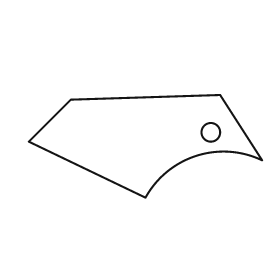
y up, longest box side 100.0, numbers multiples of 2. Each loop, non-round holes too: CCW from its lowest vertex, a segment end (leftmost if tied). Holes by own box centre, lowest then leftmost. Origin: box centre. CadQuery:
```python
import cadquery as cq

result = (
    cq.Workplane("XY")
    .moveTo(0.0, -22.0)
    .threePointArc((22.0, -4.0), (50.0, -6.0))
    .lineTo(32.0, 22.0)
    .lineTo(-32.0, 20.0)
    .lineTo(-50.0, 2.0)
    .close()
    .moveTo(28.0, 6.0)
    .circle(4.0)
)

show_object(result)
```